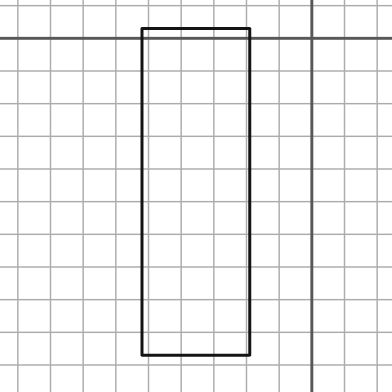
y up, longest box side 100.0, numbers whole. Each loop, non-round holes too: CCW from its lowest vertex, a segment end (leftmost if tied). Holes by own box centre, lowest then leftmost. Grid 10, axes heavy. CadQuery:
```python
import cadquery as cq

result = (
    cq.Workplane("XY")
    .moveTo(-52.0, -97.0)
    .lineTo(-19.0, -97.0)
    .lineTo(-19.0, 3.0)
    .lineTo(-52.0, 3.0)
    .close()
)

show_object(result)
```